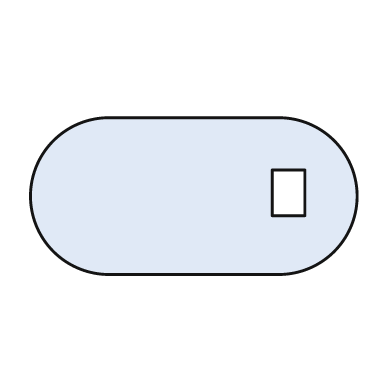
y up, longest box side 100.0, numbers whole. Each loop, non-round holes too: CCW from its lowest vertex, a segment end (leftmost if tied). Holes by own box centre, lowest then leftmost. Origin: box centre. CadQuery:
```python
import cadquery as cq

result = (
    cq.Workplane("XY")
    .moveTo(-26.0, -24.0)
    .lineTo(26.0, -24.0)
    .threePointArc((50.0, 0.0), (26.0, 24.0))
    .lineTo(-26.0, 24.0)
    .threePointArc((-50.0, 0.0), (-26.0, -24.0))
    .close()
    .moveTo(24.0, -6.0)
    .lineTo(34.0, -6.0)
    .lineTo(34.0, 8.0)
    .lineTo(24.0, 8.0)
    .close()
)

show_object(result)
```